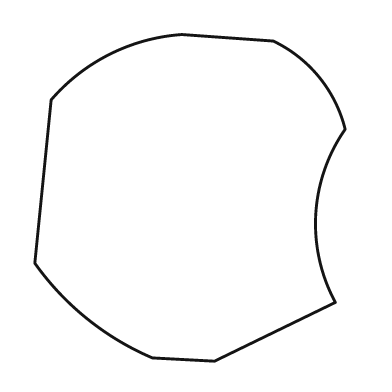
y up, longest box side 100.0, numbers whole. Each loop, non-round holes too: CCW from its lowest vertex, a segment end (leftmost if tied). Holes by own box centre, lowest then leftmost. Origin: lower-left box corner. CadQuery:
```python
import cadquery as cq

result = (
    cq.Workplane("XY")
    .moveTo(55.0, 0.0)
    .lineTo(92.0, 18.0)
    .threePointArc((86.0, 45.0), (95.0, 71.0))
    .threePointArc((87.0, 87.0), (73.0, 98.0))
    .lineTo(45.0, 100.0)
    .threePointArc((23.0, 94.0), (5.0, 80.0))
    .lineTo(0.0, 30.0)
    .threePointArc((16.0, 13.0), (36.0, 1.0))
    .close()
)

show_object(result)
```